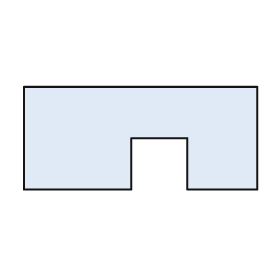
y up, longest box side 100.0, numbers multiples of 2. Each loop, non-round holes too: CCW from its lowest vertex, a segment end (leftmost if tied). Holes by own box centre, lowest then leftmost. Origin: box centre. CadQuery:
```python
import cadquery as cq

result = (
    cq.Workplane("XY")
    .moveTo(-50.0, -22.0)
    .lineTo(-4.0, -22.0)
    .lineTo(-4.0, 0.0)
    .lineTo(20.0, 0.0)
    .lineTo(20.0, -22.0)
    .lineTo(50.0, -22.0)
    .lineTo(50.0, 22.0)
    .lineTo(-50.0, 22.0)
    .close()
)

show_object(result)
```